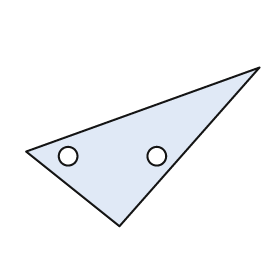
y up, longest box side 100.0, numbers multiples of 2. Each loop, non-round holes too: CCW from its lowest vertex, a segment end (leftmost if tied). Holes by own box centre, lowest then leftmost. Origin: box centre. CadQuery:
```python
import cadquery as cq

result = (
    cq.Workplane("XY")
    .moveTo(-10.0, -34.0)
    .lineTo(50.0, 34.0)
    .lineTo(-50.0, -2.0)
    .close()
    .moveTo(-32.0, -4.0)
    .circle(4.0)
    .moveTo(6.0, -4.0)
    .circle(4.0)
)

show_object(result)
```